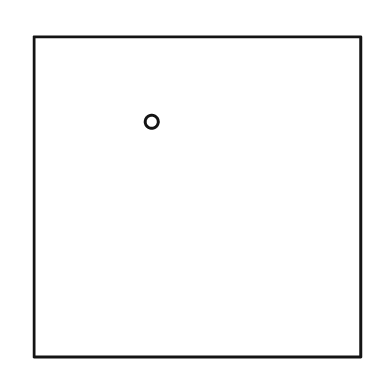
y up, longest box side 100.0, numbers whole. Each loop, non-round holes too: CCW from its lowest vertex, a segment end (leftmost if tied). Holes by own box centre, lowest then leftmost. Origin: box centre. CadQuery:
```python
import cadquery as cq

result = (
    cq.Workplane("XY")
    .moveTo(-50.0, -49.0)
    .lineTo(50.0, -49.0)
    .lineTo(50.0, 49.0)
    .lineTo(-50.0, 49.0)
    .close()
    .moveTo(-14.0, 23.0)
    .circle(2.0)
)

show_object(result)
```